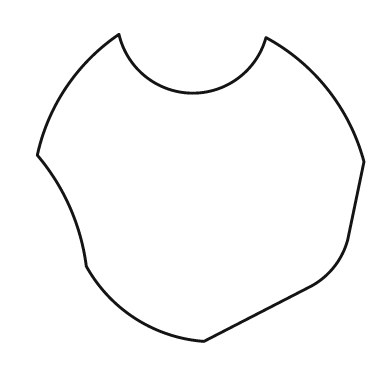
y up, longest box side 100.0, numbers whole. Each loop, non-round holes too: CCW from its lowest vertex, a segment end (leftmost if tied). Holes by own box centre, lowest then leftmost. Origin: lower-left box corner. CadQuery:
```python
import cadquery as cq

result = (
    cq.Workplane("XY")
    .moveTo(51.0, 0.0)
    .lineTo(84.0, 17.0)
    .threePointArc((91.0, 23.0), (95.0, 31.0))
    .lineTo(100.0, 55.0)
    .threePointArc((89.0, 77.0), (70.0, 93.0))
    .threePointArc((47.0, 76.0), (25.0, 94.0))
    .threePointArc((9.0, 78.0), (0.0, 57.0))
    .threePointArc((10.0, 41.0), (15.0, 23.0))
    .threePointArc((30.0, 7.0), (51.0, 0.0))
    .close()
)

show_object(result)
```